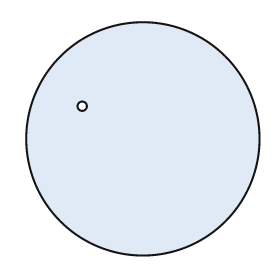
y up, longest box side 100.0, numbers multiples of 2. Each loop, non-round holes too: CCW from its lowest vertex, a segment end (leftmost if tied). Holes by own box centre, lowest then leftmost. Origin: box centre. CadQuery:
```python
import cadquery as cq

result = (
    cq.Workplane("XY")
    .moveTo(0.0, 0.0)
    .circle(50.0)
    .moveTo(-26.0, 14.0)
    .circle(2.0)
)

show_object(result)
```